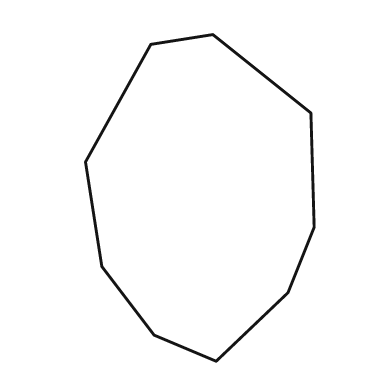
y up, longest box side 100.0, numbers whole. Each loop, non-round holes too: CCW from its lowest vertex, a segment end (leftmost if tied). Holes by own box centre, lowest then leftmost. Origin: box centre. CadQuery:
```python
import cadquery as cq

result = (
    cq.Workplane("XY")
    .moveTo(5.0, -50.0)
    .lineTo(27.0, -29.0)
    .lineTo(35.0, -9.0)
    .lineTo(34.0, 26.0)
    .lineTo(4.0, 50.0)
    .lineTo(-15.0, 47.0)
    .lineTo(-35.0, 11.0)
    .lineTo(-30.0, -21.0)
    .lineTo(-14.0, -42.0)
    .close()
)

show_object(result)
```